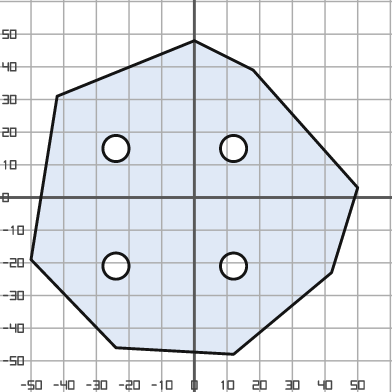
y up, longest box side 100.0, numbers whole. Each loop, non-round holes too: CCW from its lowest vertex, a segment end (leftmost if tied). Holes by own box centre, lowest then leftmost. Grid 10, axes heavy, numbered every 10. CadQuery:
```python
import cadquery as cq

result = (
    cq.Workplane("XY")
    .moveTo(12.0, -48.0)
    .lineTo(42.0, -23.0)
    .lineTo(50.0, 3.0)
    .lineTo(18.0, 39.0)
    .lineTo(0.0, 48.0)
    .lineTo(-42.0, 31.0)
    .lineTo(-50.0, -19.0)
    .lineTo(-24.0, -46.0)
    .close()
    .moveTo(-24.0, -21.0)
    .circle(4.0)
    .moveTo(12.0, -21.0)
    .circle(4.0)
    .moveTo(-24.0, 15.0)
    .circle(4.0)
    .moveTo(12.0, 15.0)
    .circle(4.0)
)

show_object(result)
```